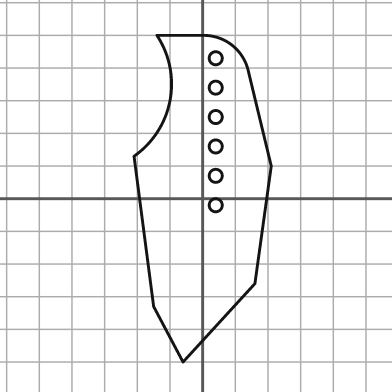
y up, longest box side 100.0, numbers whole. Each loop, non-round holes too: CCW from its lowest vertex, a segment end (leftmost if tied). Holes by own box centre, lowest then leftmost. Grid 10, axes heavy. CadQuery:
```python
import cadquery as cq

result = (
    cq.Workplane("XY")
    .moveTo(-6.0, -50.0)
    .lineTo(16.0, -26.0)
    .lineTo(21.0, 10.0)
    .lineTo(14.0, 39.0)
    .threePointArc((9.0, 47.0), (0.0, 50.0))
    .lineTo(-14.0, 50.0)
    .threePointArc((-10.0, 30.0), (-21.0, 13.0))
    .lineTo(-15.0, -33.0)
    .close()
    .moveTo(4.0, -2.0)
    .circle(2.0)
    .moveTo(4.0, 7.0)
    .circle(2.0)
    .moveTo(4.0, 16.0)
    .circle(2.0)
    .moveTo(4.0, 25.0)
    .circle(2.0)
    .moveTo(4.0, 34.0)
    .circle(2.0)
    .moveTo(4.0, 43.0)
    .circle(2.0)
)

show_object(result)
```